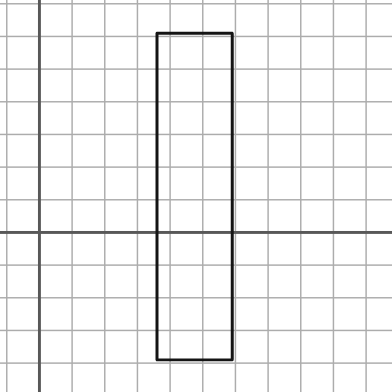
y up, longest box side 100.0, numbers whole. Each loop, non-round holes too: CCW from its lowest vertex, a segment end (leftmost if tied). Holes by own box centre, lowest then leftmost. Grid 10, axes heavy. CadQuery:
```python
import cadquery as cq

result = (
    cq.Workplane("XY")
    .moveTo(36.0, -39.0)
    .lineTo(59.0, -39.0)
    .lineTo(59.0, 61.0)
    .lineTo(36.0, 61.0)
    .close()
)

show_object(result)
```